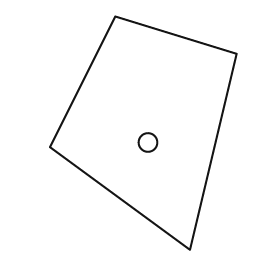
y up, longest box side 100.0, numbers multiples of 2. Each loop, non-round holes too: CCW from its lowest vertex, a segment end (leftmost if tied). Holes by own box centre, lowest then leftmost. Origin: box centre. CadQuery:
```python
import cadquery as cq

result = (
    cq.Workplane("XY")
    .moveTo(20.0, -50.0)
    .lineTo(40.0, 34.0)
    .lineTo(-12.0, 50.0)
    .lineTo(-40.0, -6.0)
    .close()
    .moveTo(2.0, -4.0)
    .circle(4.0)
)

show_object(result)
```